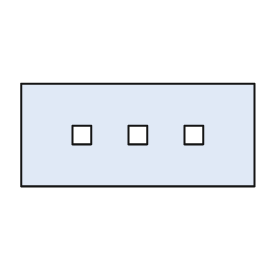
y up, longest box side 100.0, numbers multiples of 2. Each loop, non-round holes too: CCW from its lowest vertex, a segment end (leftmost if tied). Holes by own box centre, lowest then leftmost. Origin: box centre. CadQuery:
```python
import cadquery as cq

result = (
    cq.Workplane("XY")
    .moveTo(-50.0, -22.0)
    .lineTo(50.0, -22.0)
    .lineTo(50.0, 22.0)
    .lineTo(-50.0, 22.0)
    .close()
    .moveTo(-28.0, -4.0)
    .lineTo(-20.0, -4.0)
    .lineTo(-20.0, 4.0)
    .lineTo(-28.0, 4.0)
    .close()
    .moveTo(-4.0, -4.0)
    .lineTo(4.0, -4.0)
    .lineTo(4.0, 4.0)
    .lineTo(-4.0, 4.0)
    .close()
    .moveTo(20.0, -4.0)
    .lineTo(28.0, -4.0)
    .lineTo(28.0, 4.0)
    .lineTo(20.0, 4.0)
    .close()
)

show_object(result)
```